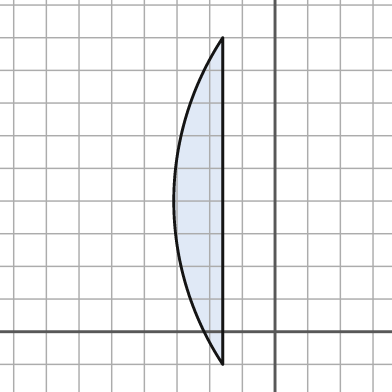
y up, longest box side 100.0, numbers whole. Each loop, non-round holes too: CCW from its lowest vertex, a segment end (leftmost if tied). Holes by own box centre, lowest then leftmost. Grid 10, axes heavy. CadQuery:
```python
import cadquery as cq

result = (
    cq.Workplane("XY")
    .moveTo(-16.0, -10.0)
    .lineTo(-16.0, 90.0)
    .threePointArc((-31.0, 40.0), (-16.0, -10.0))
    .close()
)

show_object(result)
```